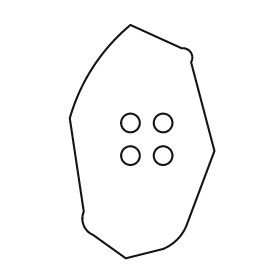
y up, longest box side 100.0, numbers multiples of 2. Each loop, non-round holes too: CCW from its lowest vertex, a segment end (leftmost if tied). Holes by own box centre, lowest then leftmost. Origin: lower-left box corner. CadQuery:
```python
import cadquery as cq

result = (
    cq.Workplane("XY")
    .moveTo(24.0, 0.0)
    .lineTo(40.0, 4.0)
    .threePointArc((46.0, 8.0), (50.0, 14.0))
    .lineTo(62.0, 46.0)
    .lineTo(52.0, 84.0)
    .threePointArc((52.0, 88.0), (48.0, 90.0))
    .lineTo(26.0, 100.0)
    .threePointArc((10.0, 82.0), (0.0, 60.0))
    .lineTo(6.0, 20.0)
    .threePointArc((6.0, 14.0), (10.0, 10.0))
    .close()
    .moveTo(26.0, 44.0)
    .circle(4.0)
    .moveTo(40.0, 44.0)
    .circle(4.0)
    .moveTo(26.0, 58.0)
    .circle(4.0)
    .moveTo(40.0, 58.0)
    .circle(4.0)
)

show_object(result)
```